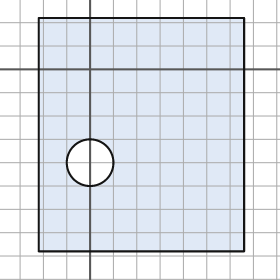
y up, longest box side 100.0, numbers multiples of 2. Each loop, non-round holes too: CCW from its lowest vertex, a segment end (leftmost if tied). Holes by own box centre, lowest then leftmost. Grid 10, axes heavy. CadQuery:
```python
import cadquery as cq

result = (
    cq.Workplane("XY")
    .moveTo(-22.0, -78.0)
    .lineTo(66.0, -78.0)
    .lineTo(66.0, 22.0)
    .lineTo(-22.0, 22.0)
    .close()
    .moveTo(0.0, -40.0)
    .circle(10.0)
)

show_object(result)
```